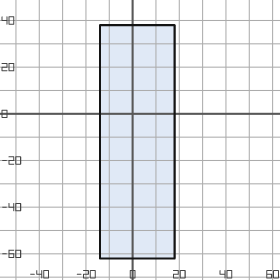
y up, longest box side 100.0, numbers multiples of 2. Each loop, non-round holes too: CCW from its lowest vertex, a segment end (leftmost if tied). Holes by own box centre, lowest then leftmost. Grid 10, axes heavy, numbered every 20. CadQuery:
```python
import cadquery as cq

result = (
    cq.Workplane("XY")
    .moveTo(-14.0, -62.0)
    .lineTo(18.0, -62.0)
    .lineTo(18.0, 38.0)
    .lineTo(-14.0, 38.0)
    .close()
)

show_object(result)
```